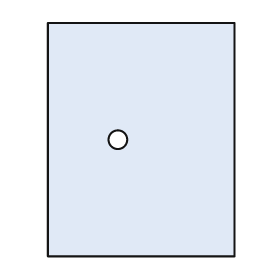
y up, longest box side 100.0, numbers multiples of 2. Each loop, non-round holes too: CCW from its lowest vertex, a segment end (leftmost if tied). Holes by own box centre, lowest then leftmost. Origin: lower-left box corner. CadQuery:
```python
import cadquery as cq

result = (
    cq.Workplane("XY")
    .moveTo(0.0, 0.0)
    .lineTo(80.0, 0.0)
    .lineTo(80.0, 100.0)
    .lineTo(0.0, 100.0)
    .close()
    .moveTo(30.0, 50.0)
    .circle(4.0)
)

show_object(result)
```